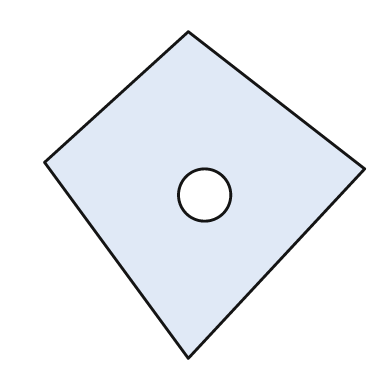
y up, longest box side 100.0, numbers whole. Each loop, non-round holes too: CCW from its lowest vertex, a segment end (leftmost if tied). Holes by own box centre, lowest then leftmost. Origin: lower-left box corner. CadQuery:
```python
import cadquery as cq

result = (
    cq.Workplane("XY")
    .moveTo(44.0, 0.0)
    .lineTo(98.0, 58.0)
    .lineTo(44.0, 100.0)
    .lineTo(0.0, 60.0)
    .close()
    .moveTo(49.0, 50.0)
    .circle(8.0)
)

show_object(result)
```